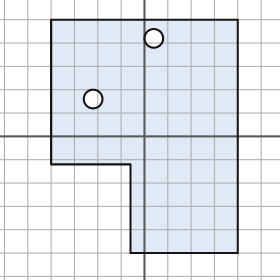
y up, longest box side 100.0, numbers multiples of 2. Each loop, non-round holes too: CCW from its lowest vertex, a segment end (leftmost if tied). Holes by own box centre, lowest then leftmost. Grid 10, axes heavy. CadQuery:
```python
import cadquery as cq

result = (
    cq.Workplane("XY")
    .moveTo(-6.0, -50.0)
    .lineTo(40.0, -50.0)
    .lineTo(40.0, 50.0)
    .lineTo(-40.0, 50.0)
    .lineTo(-40.0, -12.0)
    .lineTo(-6.0, -12.0)
    .close()
    .moveTo(-22.0, 16.0)
    .circle(4.0)
    .moveTo(4.0, 42.0)
    .circle(4.0)
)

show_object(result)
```